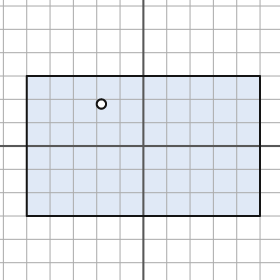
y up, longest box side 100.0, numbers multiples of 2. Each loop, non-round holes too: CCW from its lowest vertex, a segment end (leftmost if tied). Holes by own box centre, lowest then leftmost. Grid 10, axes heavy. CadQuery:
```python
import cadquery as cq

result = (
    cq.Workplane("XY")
    .moveTo(-50.0, -30.0)
    .lineTo(50.0, -30.0)
    .lineTo(50.0, 30.0)
    .lineTo(-50.0, 30.0)
    .close()
    .moveTo(-18.0, 18.0)
    .circle(2.0)
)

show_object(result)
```